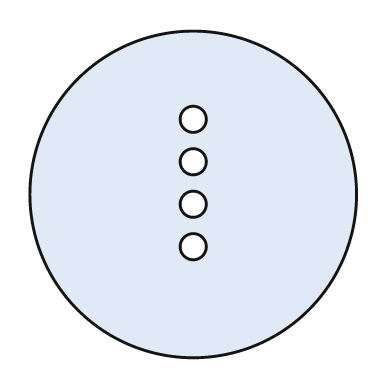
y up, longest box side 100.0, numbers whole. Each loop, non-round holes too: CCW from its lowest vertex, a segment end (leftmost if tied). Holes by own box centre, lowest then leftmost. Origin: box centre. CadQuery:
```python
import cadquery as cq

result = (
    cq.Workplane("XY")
    .moveTo(0.0, 0.0)
    .circle(50.0)
    .moveTo(0.0, -16.0)
    .circle(4.0)
    .moveTo(0.0, -3.0)
    .circle(4.0)
    .moveTo(0.0, 10.0)
    .circle(4.0)
    .moveTo(0.0, 23.0)
    .circle(4.0)
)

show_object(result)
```